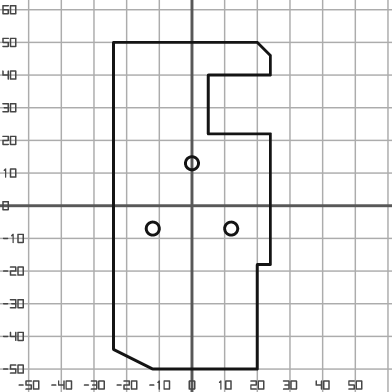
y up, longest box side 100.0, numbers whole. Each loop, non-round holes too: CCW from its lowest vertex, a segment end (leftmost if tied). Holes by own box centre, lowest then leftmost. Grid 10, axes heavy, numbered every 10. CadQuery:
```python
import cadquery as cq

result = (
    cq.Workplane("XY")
    .moveTo(-12.0, -50.0)
    .lineTo(20.0, -50.0)
    .lineTo(20.0, -18.0)
    .lineTo(24.0, -18.0)
    .lineTo(24.0, 22.0)
    .lineTo(5.0, 22.0)
    .lineTo(5.0, 40.0)
    .lineTo(24.0, 40.0)
    .lineTo(24.0, 46.0)
    .lineTo(20.0, 50.0)
    .lineTo(-24.0, 50.0)
    .lineTo(-24.0, -44.0)
    .close()
    .moveTo(-12.0, -7.0)
    .circle(2.0)
    .moveTo(12.0, -7.0)
    .circle(2.0)
    .moveTo(0.0, 13.0)
    .circle(2.0)
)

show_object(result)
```